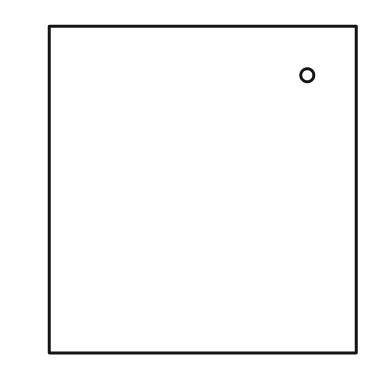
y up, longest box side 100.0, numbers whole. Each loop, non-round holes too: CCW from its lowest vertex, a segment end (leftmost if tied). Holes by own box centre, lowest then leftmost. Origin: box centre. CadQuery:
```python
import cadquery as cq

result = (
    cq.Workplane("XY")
    .moveTo(-47.0, -50.0)
    .lineTo(47.0, -50.0)
    .lineTo(47.0, 50.0)
    .lineTo(-47.0, 50.0)
    .close()
    .moveTo(32.0, 35.0)
    .circle(2.0)
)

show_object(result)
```